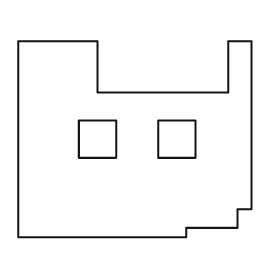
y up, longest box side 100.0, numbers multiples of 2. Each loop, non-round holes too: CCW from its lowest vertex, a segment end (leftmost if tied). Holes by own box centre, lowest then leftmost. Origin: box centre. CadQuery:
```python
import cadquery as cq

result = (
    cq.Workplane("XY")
    .moveTo(-50.0, -42.0)
    .lineTo(22.0, -42.0)
    .lineTo(22.0, -38.0)
    .lineTo(44.0, -38.0)
    .lineTo(44.0, -30.0)
    .lineTo(50.0, -30.0)
    .lineTo(50.0, 42.0)
    .lineTo(40.0, 42.0)
    .lineTo(40.0, 20.0)
    .lineTo(-16.0, 20.0)
    .lineTo(-16.0, 42.0)
    .lineTo(-50.0, 42.0)
    .close()
    .moveTo(-24.0, -8.0)
    .lineTo(-8.0, -8.0)
    .lineTo(-8.0, 8.0)
    .lineTo(-24.0, 8.0)
    .close()
    .moveTo(10.0, -8.0)
    .lineTo(26.0, -8.0)
    .lineTo(26.0, 8.0)
    .lineTo(10.0, 8.0)
    .close()
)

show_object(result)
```